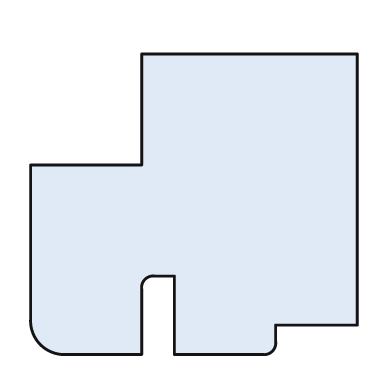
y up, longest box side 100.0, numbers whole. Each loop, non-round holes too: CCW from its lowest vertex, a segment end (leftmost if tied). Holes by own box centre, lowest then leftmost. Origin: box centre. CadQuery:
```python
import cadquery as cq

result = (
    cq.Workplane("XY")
    .moveTo(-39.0, -46.0)
    .lineTo(-16.0, -46.0)
    .lineTo(-16.0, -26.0)
    .threePointArc((-15.0, -23.0), (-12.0, -22.0))
    .lineTo(-6.0, -22.0)
    .lineTo(-6.0, -46.0)
    .lineTo(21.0, -46.0)
    .threePointArc((24.0, -45.0), (25.0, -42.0))
    .lineTo(25.0, -37.0)
    .lineTo(50.0, -37.0)
    .lineTo(50.0, 46.0)
    .lineTo(-16.0, 46.0)
    .lineTo(-16.0, 12.0)
    .lineTo(-50.0, 12.0)
    .lineTo(-50.0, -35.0)
    .threePointArc((-47.0, -43.0), (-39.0, -46.0))
    .close()
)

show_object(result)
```